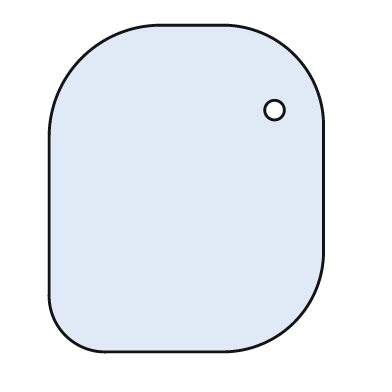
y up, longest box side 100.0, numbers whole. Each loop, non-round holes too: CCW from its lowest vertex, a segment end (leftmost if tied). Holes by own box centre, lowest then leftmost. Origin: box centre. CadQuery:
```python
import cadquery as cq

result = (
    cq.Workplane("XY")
    .moveTo(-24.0, -50.0)
    .lineTo(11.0, -50.0)
    .threePointArc((33.0, -41.0), (42.0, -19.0))
    .lineTo(42.0, 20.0)
    .threePointArc((33.0, 41.0), (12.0, 50.0))
    .lineTo(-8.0, 50.0)
    .threePointArc((-32.0, 40.0), (-42.0, 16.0))
    .lineTo(-42.0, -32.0)
    .threePointArc((-37.0, -45.0), (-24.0, -50.0))
    .close()
    .moveTo(27.0, 24.0)
    .circle(3.0)
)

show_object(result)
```